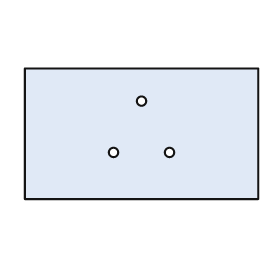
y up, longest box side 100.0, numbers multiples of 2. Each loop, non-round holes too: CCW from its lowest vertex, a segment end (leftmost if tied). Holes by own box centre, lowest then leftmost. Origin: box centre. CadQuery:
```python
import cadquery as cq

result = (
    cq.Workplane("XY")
    .moveTo(-50.0, -28.0)
    .lineTo(50.0, -28.0)
    .lineTo(50.0, 28.0)
    .lineTo(-50.0, 28.0)
    .close()
    .moveTo(-12.0, -8.0)
    .circle(2.0)
    .moveTo(12.0, -8.0)
    .circle(2.0)
    .moveTo(0.0, 14.0)
    .circle(2.0)
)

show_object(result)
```